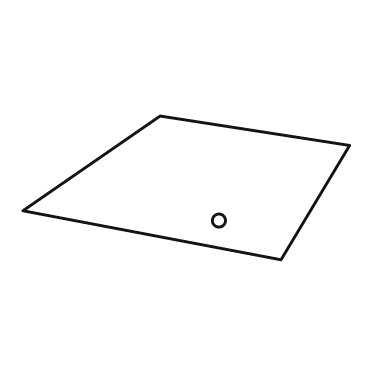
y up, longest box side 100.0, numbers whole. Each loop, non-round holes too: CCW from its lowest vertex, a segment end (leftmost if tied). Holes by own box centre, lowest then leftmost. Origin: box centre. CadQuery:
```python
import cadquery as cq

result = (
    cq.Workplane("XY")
    .moveTo(29.0, -22.0)
    .lineTo(50.0, 13.0)
    .lineTo(-8.0, 22.0)
    .lineTo(-50.0, -7.0)
    .close()
    .moveTo(10.0, -10.0)
    .circle(2.0)
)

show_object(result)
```